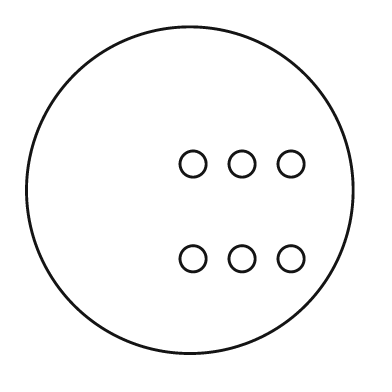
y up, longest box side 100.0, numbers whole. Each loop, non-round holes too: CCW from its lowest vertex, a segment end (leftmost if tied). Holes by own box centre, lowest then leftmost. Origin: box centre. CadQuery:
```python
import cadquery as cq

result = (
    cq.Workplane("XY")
    .moveTo(0.0, 0.0)
    .circle(50.0)
    .moveTo(1.0, -21.0)
    .circle(4.0)
    .moveTo(16.0, -21.0)
    .circle(4.0)
    .moveTo(31.0, -21.0)
    .circle(4.0)
    .moveTo(1.0, 8.0)
    .circle(4.0)
    .moveTo(16.0, 8.0)
    .circle(4.0)
    .moveTo(31.0, 8.0)
    .circle(4.0)
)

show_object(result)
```